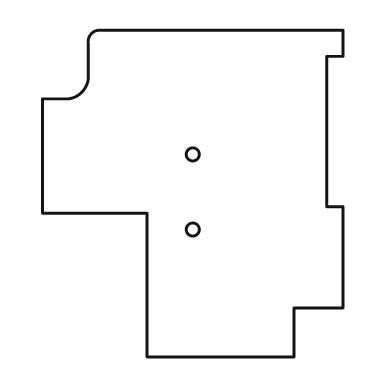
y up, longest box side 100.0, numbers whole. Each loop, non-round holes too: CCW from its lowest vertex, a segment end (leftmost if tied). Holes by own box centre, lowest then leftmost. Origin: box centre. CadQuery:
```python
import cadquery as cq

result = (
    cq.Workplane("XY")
    .moveTo(-14.0, -50.0)
    .lineTo(31.0, -50.0)
    .lineTo(31.0, -35.0)
    .lineTo(46.0, -35.0)
    .lineTo(46.0, -4.0)
    .lineTo(41.0, -4.0)
    .lineTo(41.0, 42.0)
    .lineTo(46.0, 42.0)
    .lineTo(46.0, 50.0)
    .lineTo(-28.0, 50.0)
    .threePointArc((-31.0, 49.0), (-32.0, 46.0))
    .lineTo(-32.0, 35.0)
    .threePointArc((-34.0, 31.0), (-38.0, 29.0))
    .lineTo(-46.0, 29.0)
    .lineTo(-46.0, -6.0)
    .lineTo(-14.0, -6.0)
    .close()
    .moveTo(0.0, -11.0)
    .circle(2.0)
    .moveTo(0.0, 12.0)
    .circle(2.0)
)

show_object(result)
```